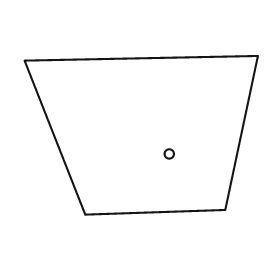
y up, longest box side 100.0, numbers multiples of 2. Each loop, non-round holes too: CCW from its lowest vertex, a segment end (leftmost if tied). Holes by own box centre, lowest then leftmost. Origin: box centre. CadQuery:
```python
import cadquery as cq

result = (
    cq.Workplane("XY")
    .moveTo(-24.0, -34.0)
    .lineTo(36.0, -32.0)
    .lineTo(50.0, 34.0)
    .lineTo(-50.0, 32.0)
    .close()
    .moveTo(12.0, -8.0)
    .circle(2.0)
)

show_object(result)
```